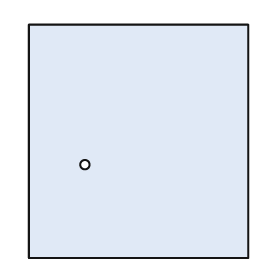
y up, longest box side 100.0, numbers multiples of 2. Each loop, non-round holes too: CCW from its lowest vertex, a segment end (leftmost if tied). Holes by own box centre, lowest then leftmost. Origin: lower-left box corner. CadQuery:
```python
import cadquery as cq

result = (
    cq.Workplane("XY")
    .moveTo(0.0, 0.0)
    .lineTo(94.0, 0.0)
    .lineTo(94.0, 100.0)
    .lineTo(0.0, 100.0)
    .close()
    .moveTo(24.0, 40.0)
    .circle(2.0)
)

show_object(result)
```